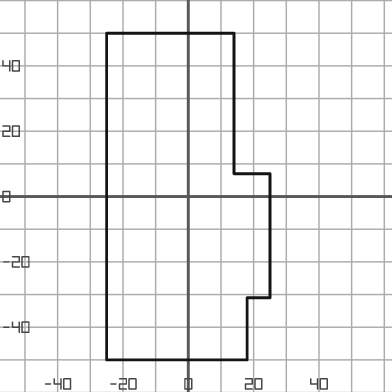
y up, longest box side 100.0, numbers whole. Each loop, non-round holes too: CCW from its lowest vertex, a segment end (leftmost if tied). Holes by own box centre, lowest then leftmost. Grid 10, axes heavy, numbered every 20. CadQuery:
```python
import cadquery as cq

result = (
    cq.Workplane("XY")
    .moveTo(-25.0, -50.0)
    .lineTo(18.0, -50.0)
    .lineTo(18.0, -31.0)
    .lineTo(25.0, -31.0)
    .lineTo(25.0, 7.0)
    .lineTo(14.0, 7.0)
    .lineTo(14.0, 50.0)
    .lineTo(-25.0, 50.0)
    .close()
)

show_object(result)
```